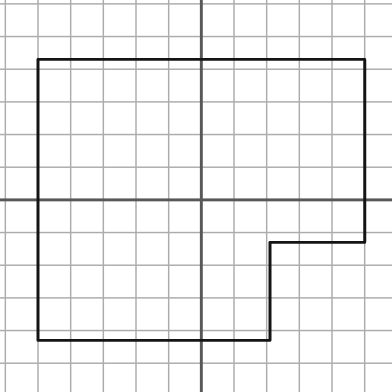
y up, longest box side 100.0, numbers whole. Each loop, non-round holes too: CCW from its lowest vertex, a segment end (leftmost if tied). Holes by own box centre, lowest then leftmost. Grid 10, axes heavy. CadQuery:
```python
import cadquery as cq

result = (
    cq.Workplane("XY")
    .moveTo(-50.0, -43.0)
    .lineTo(21.0, -43.0)
    .lineTo(21.0, -13.0)
    .lineTo(50.0, -13.0)
    .lineTo(50.0, 43.0)
    .lineTo(-50.0, 43.0)
    .close()
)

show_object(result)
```